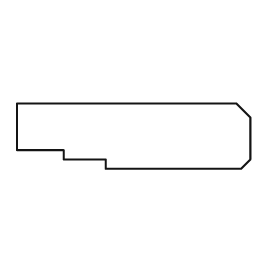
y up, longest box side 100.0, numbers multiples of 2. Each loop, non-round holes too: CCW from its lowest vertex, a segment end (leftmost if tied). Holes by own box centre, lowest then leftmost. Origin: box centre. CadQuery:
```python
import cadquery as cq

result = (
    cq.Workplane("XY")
    .moveTo(-12.0, -14.0)
    .lineTo(46.0, -14.0)
    .lineTo(50.0, -10.0)
    .lineTo(50.0, 8.0)
    .lineTo(44.0, 14.0)
    .lineTo(-50.0, 14.0)
    .lineTo(-50.0, -6.0)
    .lineTo(-30.0, -6.0)
    .lineTo(-30.0, -10.0)
    .lineTo(-12.0, -10.0)
    .close()
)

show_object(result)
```